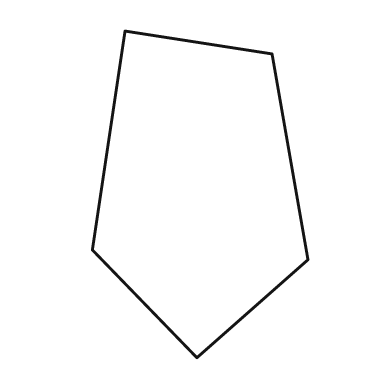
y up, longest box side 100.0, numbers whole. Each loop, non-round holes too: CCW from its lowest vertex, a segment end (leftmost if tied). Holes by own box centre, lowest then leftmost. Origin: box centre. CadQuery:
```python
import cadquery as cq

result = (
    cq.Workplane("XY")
    .moveTo(-1.0, -50.0)
    .lineTo(33.0, -20.0)
    .lineTo(22.0, 43.0)
    .lineTo(-23.0, 50.0)
    .lineTo(-33.0, -17.0)
    .close()
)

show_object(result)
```